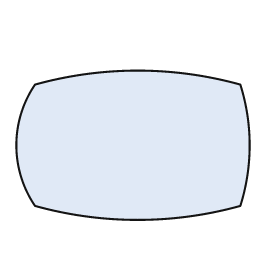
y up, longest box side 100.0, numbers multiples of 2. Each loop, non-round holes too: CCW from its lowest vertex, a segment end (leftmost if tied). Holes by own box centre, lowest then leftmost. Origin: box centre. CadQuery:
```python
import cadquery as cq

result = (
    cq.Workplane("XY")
    .moveTo(-42.0, -26.0)
    .threePointArc((2.0, -32.0), (46.0, -26.0))
    .threePointArc((50.0, 0.0), (46.0, 26.0))
    .threePointArc((2.0, 32.0), (-42.0, 26.0))
    .threePointArc((-50.0, 0.0), (-42.0, -26.0))
    .close()
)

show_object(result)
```